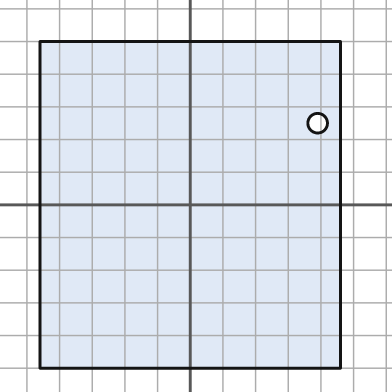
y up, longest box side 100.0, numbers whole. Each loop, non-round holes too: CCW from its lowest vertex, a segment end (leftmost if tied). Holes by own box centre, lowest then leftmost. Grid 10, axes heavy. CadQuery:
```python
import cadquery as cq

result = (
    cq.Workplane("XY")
    .moveTo(-46.0, -50.0)
    .lineTo(46.0, -50.0)
    .lineTo(46.0, 50.0)
    .lineTo(-46.0, 50.0)
    .close()
    .moveTo(39.0, 25.0)
    .circle(3.0)
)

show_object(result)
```